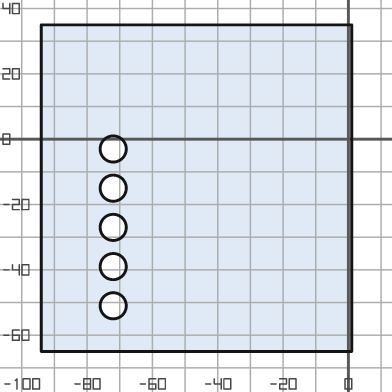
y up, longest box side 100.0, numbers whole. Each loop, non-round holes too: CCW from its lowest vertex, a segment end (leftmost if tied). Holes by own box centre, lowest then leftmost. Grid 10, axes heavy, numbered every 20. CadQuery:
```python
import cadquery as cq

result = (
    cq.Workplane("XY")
    .moveTo(-94.0, -65.0)
    .lineTo(1.0, -65.0)
    .lineTo(1.0, 35.0)
    .lineTo(-94.0, 35.0)
    .close()
    .moveTo(-72.0, -51.0)
    .circle(4.0)
    .moveTo(-72.0, -39.0)
    .circle(4.0)
    .moveTo(-72.0, -27.0)
    .circle(4.0)
    .moveTo(-72.0, -15.0)
    .circle(4.0)
    .moveTo(-72.0, -3.0)
    .circle(4.0)
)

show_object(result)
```